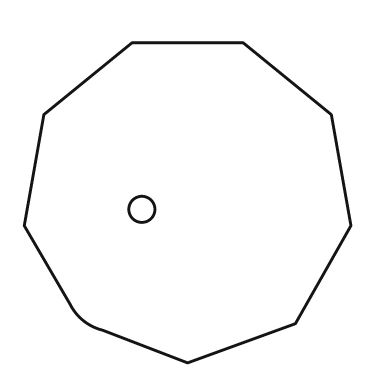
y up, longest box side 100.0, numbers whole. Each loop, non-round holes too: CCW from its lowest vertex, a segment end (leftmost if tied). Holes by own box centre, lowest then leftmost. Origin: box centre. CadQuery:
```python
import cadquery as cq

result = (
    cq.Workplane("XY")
    .moveTo(0.0, -49.0)
    .lineTo(33.0, -37.0)
    .lineTo(50.0, -7.0)
    .lineTo(44.0, 27.0)
    .lineTo(17.0, 49.0)
    .lineTo(-17.0, 49.0)
    .lineTo(-44.0, 27.0)
    .lineTo(-50.0, -7.0)
    .lineTo(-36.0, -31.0)
    .threePointArc((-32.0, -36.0), (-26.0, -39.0))
    .close()
    .moveTo(-14.0, -2.0)
    .circle(4.0)
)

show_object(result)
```